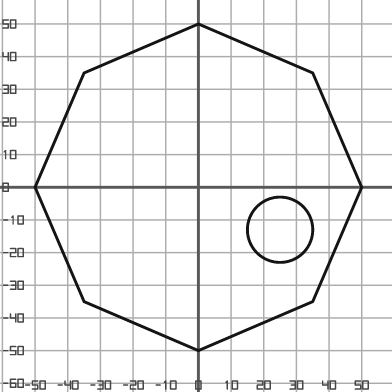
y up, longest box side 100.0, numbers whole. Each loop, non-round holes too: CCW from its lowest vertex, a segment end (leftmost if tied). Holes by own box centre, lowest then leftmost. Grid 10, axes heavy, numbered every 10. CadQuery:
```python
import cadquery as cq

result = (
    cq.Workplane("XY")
    .moveTo(0.0, -50.0)
    .lineTo(35.0, -35.0)
    .lineTo(50.0, 0.0)
    .lineTo(35.0, 35.0)
    .lineTo(0.0, 50.0)
    .lineTo(-35.0, 35.0)
    .lineTo(-50.0, 0.0)
    .lineTo(-35.0, -35.0)
    .close()
    .moveTo(25.0, -13.0)
    .circle(10.0)
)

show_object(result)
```